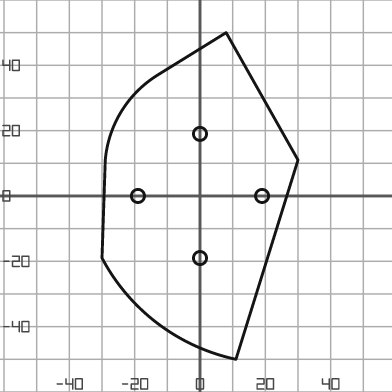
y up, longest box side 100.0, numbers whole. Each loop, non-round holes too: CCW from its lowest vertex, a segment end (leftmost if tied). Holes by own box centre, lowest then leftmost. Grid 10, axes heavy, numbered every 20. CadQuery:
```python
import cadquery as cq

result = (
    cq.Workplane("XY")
    .moveTo(11.0, -50.0)
    .lineTo(30.0, 11.0)
    .lineTo(8.0, 50.0)
    .lineTo(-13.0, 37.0)
    .threePointArc((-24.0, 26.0), (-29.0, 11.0))
    .lineTo(-30.0, -19.0)
    .threePointArc((-13.0, -39.0), (11.0, -50.0))
    .close()
    .moveTo(0.0, -19.0)
    .circle(2.0)
    .moveTo(-19.0, 0.0)
    .circle(2.0)
    .moveTo(19.0, 0.0)
    .circle(2.0)
    .moveTo(0.0, 19.0)
    .circle(2.0)
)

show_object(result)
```